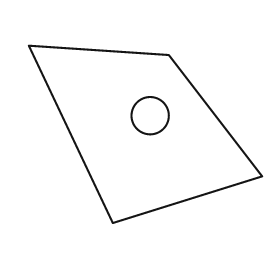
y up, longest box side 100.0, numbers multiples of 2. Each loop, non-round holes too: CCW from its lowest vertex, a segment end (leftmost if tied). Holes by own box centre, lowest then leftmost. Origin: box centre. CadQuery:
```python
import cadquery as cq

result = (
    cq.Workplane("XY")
    .moveTo(-14.0, -38.0)
    .lineTo(50.0, -18.0)
    .lineTo(10.0, 34.0)
    .lineTo(-50.0, 38.0)
    .close()
    .moveTo(2.0, 8.0)
    .circle(8.0)
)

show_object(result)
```